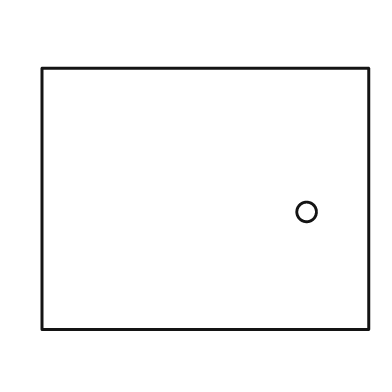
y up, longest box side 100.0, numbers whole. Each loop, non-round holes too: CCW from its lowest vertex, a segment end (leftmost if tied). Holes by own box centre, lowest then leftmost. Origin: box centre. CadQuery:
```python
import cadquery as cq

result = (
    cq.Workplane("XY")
    .moveTo(-50.0, -40.0)
    .lineTo(50.0, -40.0)
    .lineTo(50.0, 40.0)
    .lineTo(-50.0, 40.0)
    .close()
    .moveTo(31.0, -4.0)
    .circle(3.0)
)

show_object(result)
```